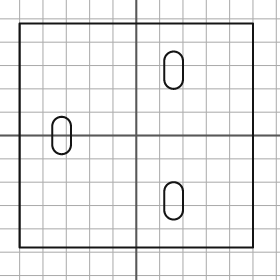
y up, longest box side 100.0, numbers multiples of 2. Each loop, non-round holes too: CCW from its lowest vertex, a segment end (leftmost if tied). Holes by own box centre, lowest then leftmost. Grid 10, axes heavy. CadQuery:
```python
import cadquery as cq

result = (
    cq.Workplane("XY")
    .moveTo(-50.0, -48.0)
    .lineTo(50.0, -48.0)
    .lineTo(50.0, 48.0)
    .lineTo(-50.0, 48.0)
    .close()
    .moveTo(12.0, -32.0)
    .threePointArc((16.0, -36.0), (20.0, -32.0))
    .lineTo(20.0, -24.0)
    .threePointArc((16.0, -20.0), (12.0, -24.0))
    .close()
    .moveTo(-36.0, -4.0)
    .threePointArc((-32.0, -8.0), (-28.0, -4.0))
    .lineTo(-28.0, 4.0)
    .threePointArc((-32.0, 8.0), (-36.0, 4.0))
    .close()
    .moveTo(12.0, 24.0)
    .threePointArc((16.0, 20.0), (20.0, 24.0))
    .lineTo(20.0, 32.0)
    .threePointArc((16.0, 36.0), (12.0, 32.0))
    .close()
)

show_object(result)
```